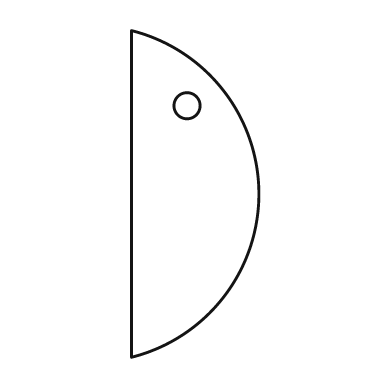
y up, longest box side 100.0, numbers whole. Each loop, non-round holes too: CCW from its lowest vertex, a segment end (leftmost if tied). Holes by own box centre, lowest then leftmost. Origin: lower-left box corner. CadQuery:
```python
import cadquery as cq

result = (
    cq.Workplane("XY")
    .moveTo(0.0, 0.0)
    .threePointArc((39.0, 50.0), (0.0, 100.0))
    .close()
    .moveTo(17.0, 77.0)
    .circle(4.0)
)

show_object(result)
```